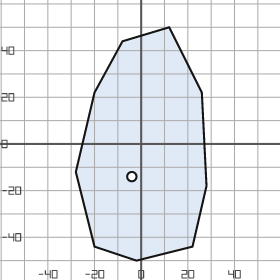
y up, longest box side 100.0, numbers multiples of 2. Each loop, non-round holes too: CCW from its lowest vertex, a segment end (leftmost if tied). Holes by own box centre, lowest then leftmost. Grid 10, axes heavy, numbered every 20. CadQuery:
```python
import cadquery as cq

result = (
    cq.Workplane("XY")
    .moveTo(-2.0, -50.0)
    .lineTo(22.0, -44.0)
    .lineTo(28.0, -18.0)
    .lineTo(26.0, 22.0)
    .lineTo(12.0, 50.0)
    .lineTo(-8.0, 44.0)
    .lineTo(-20.0, 22.0)
    .lineTo(-28.0, -12.0)
    .lineTo(-20.0, -44.0)
    .close()
    .moveTo(-4.0, -14.0)
    .circle(2.0)
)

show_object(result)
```